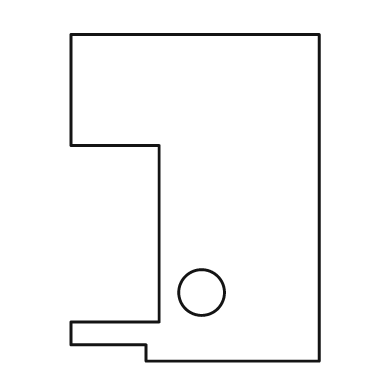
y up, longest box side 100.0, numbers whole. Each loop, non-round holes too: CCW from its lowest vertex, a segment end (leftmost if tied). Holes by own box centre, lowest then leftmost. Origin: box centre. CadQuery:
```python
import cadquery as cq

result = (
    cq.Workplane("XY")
    .moveTo(-15.0, -50.0)
    .lineTo(38.0, -50.0)
    .lineTo(38.0, 50.0)
    .lineTo(-38.0, 50.0)
    .lineTo(-38.0, 16.0)
    .lineTo(-11.0, 16.0)
    .lineTo(-11.0, -38.0)
    .lineTo(-38.0, -38.0)
    .lineTo(-38.0, -45.0)
    .lineTo(-15.0, -45.0)
    .close()
    .moveTo(2.0, -29.0)
    .circle(7.0)
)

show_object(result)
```